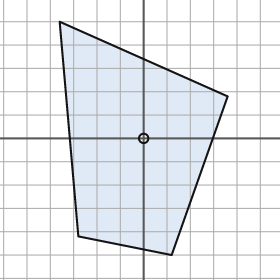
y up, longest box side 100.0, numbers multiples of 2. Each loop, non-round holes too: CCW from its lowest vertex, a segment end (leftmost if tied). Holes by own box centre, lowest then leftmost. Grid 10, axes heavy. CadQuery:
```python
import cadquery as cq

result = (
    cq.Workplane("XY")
    .moveTo(12.0, -50.0)
    .lineTo(36.0, 18.0)
    .lineTo(-36.0, 50.0)
    .lineTo(-28.0, -42.0)
    .close()
    .moveTo(0.0, 0.0)
    .circle(2.0)
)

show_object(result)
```